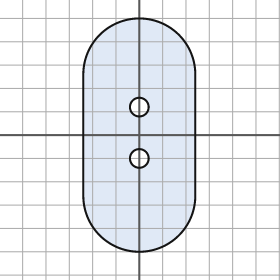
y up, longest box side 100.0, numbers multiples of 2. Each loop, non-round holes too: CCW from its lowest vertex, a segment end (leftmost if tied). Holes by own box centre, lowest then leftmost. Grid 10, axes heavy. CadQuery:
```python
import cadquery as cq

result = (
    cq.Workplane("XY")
    .moveTo(-24.0, -26.0)
    .threePointArc((0.0, -50.0), (24.0, -26.0))
    .lineTo(24.0, 26.0)
    .threePointArc((0.0, 50.0), (-24.0, 26.0))
    .close()
    .moveTo(0.0, -10.0)
    .circle(4.0)
    .moveTo(0.0, 12.0)
    .circle(4.0)
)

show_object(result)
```